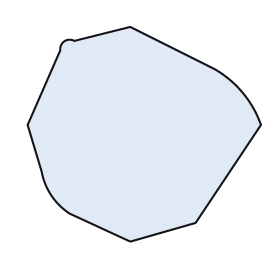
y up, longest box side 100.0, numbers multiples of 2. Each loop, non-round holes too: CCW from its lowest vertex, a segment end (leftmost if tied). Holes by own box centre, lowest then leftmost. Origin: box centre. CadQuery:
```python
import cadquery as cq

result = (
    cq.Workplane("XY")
    .moveTo(-6.0, -46.0)
    .lineTo(22.0, -38.0)
    .lineTo(50.0, 4.0)
    .threePointArc((42.0, 18.0), (30.0, 28.0))
    .lineTo(-6.0, 46.0)
    .lineTo(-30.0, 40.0)
    .threePointArc((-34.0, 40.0), (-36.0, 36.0))
    .lineTo(-50.0, 4.0)
    .lineTo(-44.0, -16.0)
    .threePointArc((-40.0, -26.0), (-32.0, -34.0))
    .close()
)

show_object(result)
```